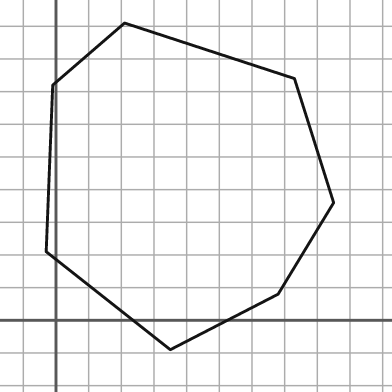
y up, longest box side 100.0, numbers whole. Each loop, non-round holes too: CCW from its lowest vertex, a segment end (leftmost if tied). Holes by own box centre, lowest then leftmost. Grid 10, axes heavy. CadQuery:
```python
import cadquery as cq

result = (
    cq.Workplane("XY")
    .moveTo(35.0, -9.0)
    .lineTo(68.0, 8.0)
    .lineTo(85.0, 36.0)
    .lineTo(73.0, 74.0)
    .lineTo(21.0, 91.0)
    .lineTo(-1.0, 72.0)
    .lineTo(-3.0, 21.0)
    .close()
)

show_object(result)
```